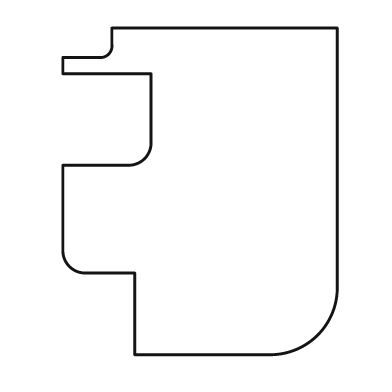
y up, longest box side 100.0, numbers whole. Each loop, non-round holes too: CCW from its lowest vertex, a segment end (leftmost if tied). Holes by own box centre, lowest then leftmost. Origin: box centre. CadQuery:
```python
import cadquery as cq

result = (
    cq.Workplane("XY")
    .moveTo(-20.0, -50.0)
    .lineTo(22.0, -50.0)
    .threePointArc((36.0, -44.0), (42.0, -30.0))
    .lineTo(42.0, 50.0)
    .lineTo(-27.0, 50.0)
    .lineTo(-27.0, 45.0)
    .threePointArc((-28.0, 42.0), (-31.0, 41.0))
    .lineTo(-42.0, 41.0)
    .lineTo(-42.0, 36.0)
    .lineTo(-15.0, 36.0)
    .lineTo(-15.0, 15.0)
    .threePointArc((-17.0, 10.0), (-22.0, 8.0))
    .lineTo(-42.0, 8.0)
    .lineTo(-42.0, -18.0)
    .threePointArc((-40.0, -23.0), (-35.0, -25.0))
    .lineTo(-20.0, -25.0)
    .close()
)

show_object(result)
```